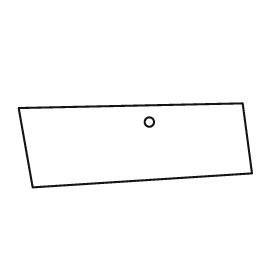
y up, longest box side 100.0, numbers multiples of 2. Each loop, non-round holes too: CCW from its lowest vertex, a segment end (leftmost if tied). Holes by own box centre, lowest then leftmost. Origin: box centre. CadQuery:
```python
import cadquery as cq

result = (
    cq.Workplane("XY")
    .moveTo(-44.0, -18.0)
    .lineTo(50.0, -12.0)
    .lineTo(46.0, 18.0)
    .lineTo(-50.0, 16.0)
    .close()
    .moveTo(6.0, 10.0)
    .circle(2.0)
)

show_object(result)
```